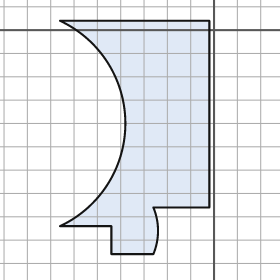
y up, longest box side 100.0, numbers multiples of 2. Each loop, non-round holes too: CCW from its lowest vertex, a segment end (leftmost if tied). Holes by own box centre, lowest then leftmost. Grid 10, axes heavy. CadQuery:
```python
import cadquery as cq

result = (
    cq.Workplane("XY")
    .moveTo(-44.0, -96.0)
    .lineTo(-26.0, -96.0)
    .threePointArc((-24.0, -86.0), (-26.0, -76.0))
    .lineTo(-2.0, -76.0)
    .lineTo(-2.0, 4.0)
    .lineTo(-66.0, 4.0)
    .threePointArc((-38.0, -40.0), (-66.0, -84.0))
    .lineTo(-44.0, -84.0)
    .close()
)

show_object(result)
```